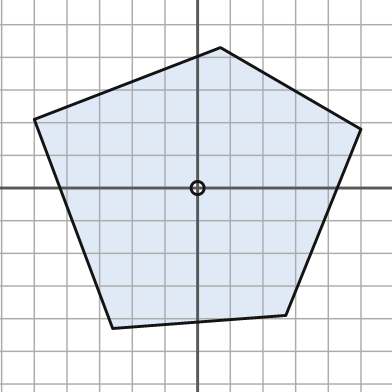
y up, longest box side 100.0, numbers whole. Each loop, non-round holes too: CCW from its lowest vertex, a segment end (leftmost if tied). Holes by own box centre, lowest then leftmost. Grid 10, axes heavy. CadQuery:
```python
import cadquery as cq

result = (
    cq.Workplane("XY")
    .moveTo(-26.0, -43.0)
    .lineTo(27.0, -39.0)
    .lineTo(50.0, 18.0)
    .lineTo(7.0, 43.0)
    .lineTo(-50.0, 21.0)
    .close()
    .moveTo(0.0, 0.0)
    .circle(2.0)
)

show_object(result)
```